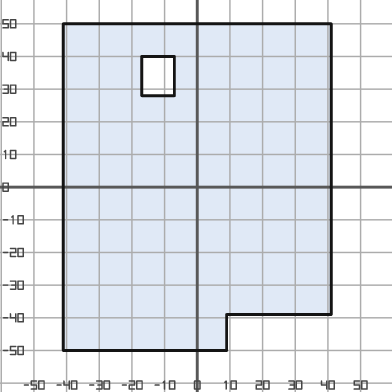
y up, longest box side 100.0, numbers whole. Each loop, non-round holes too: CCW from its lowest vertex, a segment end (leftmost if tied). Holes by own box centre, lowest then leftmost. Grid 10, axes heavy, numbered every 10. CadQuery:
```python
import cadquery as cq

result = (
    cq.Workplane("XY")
    .moveTo(-41.0, -50.0)
    .lineTo(9.0, -50.0)
    .lineTo(9.0, -39.0)
    .lineTo(41.0, -39.0)
    .lineTo(41.0, 50.0)
    .lineTo(-41.0, 50.0)
    .close()
    .moveTo(-17.0, 28.0)
    .lineTo(-7.0, 28.0)
    .lineTo(-7.0, 40.0)
    .lineTo(-17.0, 40.0)
    .close()
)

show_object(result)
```